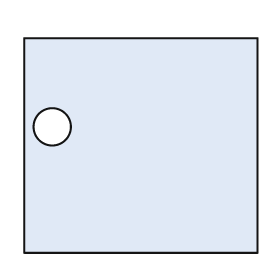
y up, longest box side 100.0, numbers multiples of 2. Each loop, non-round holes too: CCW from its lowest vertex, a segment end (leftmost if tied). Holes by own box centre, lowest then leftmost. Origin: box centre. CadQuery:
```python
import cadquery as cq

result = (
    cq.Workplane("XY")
    .moveTo(-50.0, -46.0)
    .lineTo(50.0, -46.0)
    .lineTo(50.0, 46.0)
    .lineTo(-50.0, 46.0)
    .close()
    .moveTo(-38.0, 8.0)
    .circle(8.0)
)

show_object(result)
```